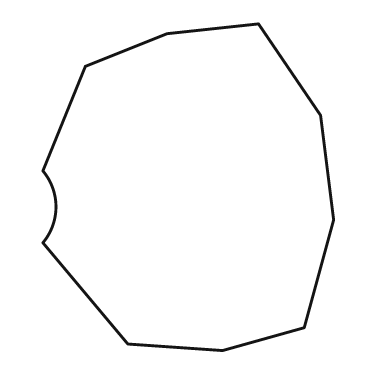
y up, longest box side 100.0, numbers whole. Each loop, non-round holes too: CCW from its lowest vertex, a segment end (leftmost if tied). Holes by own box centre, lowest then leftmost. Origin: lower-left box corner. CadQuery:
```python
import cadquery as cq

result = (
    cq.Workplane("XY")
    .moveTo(55.0, 0.0)
    .lineTo(80.0, 7.0)
    .lineTo(89.0, 40.0)
    .lineTo(85.0, 72.0)
    .lineTo(66.0, 100.0)
    .lineTo(38.0, 97.0)
    .lineTo(13.0, 87.0)
    .lineTo(0.0, 55.0)
    .threePointArc((4.0, 44.0), (0.0, 33.0))
    .lineTo(26.0, 2.0)
    .close()
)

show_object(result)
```